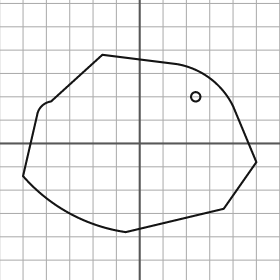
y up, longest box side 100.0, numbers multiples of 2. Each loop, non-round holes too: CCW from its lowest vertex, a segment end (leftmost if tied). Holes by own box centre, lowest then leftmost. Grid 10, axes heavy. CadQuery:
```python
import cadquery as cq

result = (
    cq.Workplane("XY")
    .moveTo(-6.0, -38.0)
    .lineTo(36.0, -28.0)
    .lineTo(50.0, -8.0)
    .lineTo(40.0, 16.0)
    .threePointArc((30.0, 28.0), (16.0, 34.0))
    .lineTo(-16.0, 38.0)
    .lineTo(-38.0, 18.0)
    .threePointArc((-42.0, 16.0), (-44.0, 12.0))
    .lineTo(-50.0, -14.0)
    .threePointArc((-30.0, -30.0), (-6.0, -38.0))
    .close()
    .moveTo(24.0, 20.0)
    .circle(2.0)
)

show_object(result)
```